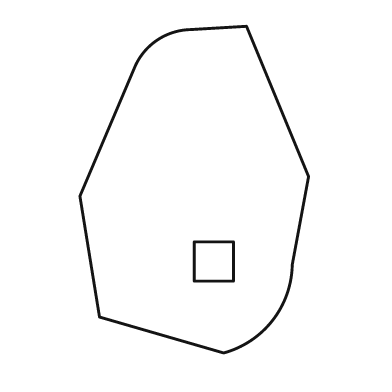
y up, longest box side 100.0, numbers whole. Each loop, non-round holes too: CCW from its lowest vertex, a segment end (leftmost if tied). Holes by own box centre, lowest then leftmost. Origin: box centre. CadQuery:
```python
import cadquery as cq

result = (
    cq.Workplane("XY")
    .moveTo(9.0, -50.0)
    .threePointArc((24.0, -40.0), (30.0, -23.0))
    .lineTo(35.0, 4.0)
    .lineTo(16.0, 50.0)
    .lineTo(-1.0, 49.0)
    .threePointArc((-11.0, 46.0), (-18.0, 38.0))
    .lineTo(-35.0, -2.0)
    .lineTo(-29.0, -39.0)
    .close()
    .moveTo(0.0, -28.0)
    .lineTo(12.0, -28.0)
    .lineTo(12.0, -16.0)
    .lineTo(0.0, -16.0)
    .close()
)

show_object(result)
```